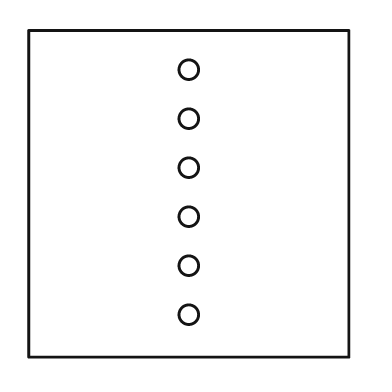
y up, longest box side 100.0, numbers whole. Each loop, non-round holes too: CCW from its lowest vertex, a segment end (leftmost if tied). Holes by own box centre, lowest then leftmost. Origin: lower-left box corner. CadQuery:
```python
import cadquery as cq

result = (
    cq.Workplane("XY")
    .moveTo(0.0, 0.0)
    .lineTo(98.0, 0.0)
    .lineTo(98.0, 100.0)
    .lineTo(0.0, 100.0)
    .close()
    .moveTo(49.0, 13.0)
    .circle(3.0)
    .moveTo(49.0, 28.0)
    .circle(3.0)
    .moveTo(49.0, 43.0)
    .circle(3.0)
    .moveTo(49.0, 58.0)
    .circle(3.0)
    .moveTo(49.0, 73.0)
    .circle(3.0)
    .moveTo(49.0, 88.0)
    .circle(3.0)
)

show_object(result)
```